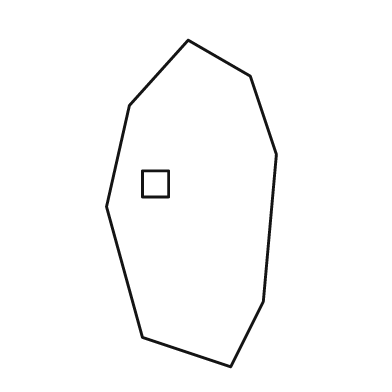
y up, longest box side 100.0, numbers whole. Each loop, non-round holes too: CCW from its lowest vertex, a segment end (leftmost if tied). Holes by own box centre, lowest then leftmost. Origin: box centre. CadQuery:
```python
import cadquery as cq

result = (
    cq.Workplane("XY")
    .moveTo(12.0, -50.0)
    .lineTo(22.0, -30.0)
    .lineTo(26.0, 15.0)
    .lineTo(18.0, 39.0)
    .lineTo(-1.0, 50.0)
    .lineTo(-19.0, 30.0)
    .lineTo(-26.0, -1.0)
    .lineTo(-15.0, -41.0)
    .close()
    .moveTo(-15.0, 2.0)
    .lineTo(-7.0, 2.0)
    .lineTo(-7.0, 10.0)
    .lineTo(-15.0, 10.0)
    .close()
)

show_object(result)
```